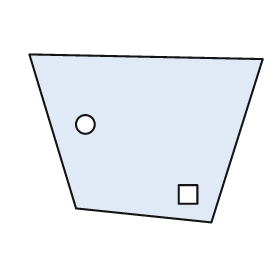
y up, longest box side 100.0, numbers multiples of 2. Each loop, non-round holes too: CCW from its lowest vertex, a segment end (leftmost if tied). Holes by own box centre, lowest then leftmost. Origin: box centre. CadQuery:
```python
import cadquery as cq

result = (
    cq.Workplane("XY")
    .moveTo(28.0, -36.0)
    .lineTo(50.0, 34.0)
    .lineTo(-50.0, 36.0)
    .lineTo(-30.0, -30.0)
    .close()
    .moveTo(14.0, -28.0)
    .lineTo(22.0, -28.0)
    .lineTo(22.0, -20.0)
    .lineTo(14.0, -20.0)
    .close()
    .moveTo(-26.0, 6.0)
    .circle(4.0)
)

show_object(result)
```